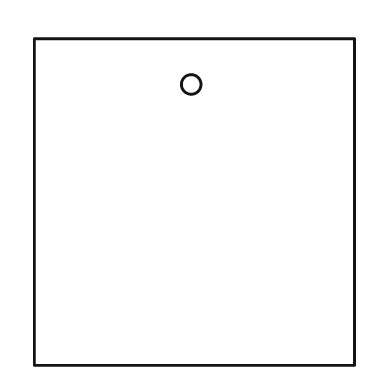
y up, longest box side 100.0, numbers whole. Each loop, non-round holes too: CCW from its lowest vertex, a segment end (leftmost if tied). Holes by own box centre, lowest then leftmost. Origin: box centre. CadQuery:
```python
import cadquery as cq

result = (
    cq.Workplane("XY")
    .moveTo(-49.0, -50.0)
    .lineTo(49.0, -50.0)
    .lineTo(49.0, 50.0)
    .lineTo(-49.0, 50.0)
    .close()
    .moveTo(-1.0, 36.0)
    .circle(3.0)
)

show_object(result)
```